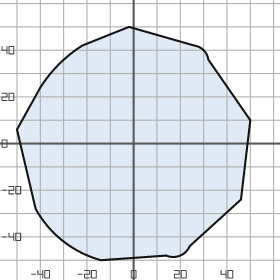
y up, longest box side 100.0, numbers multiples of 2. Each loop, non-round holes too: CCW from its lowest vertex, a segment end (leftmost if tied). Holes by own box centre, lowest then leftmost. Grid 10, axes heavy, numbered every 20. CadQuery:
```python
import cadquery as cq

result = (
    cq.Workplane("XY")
    .moveTo(-14.0, -50.0)
    .lineTo(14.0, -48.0)
    .threePointArc((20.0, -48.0), (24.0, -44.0))
    .lineTo(46.0, -24.0)
    .lineTo(50.0, 10.0)
    .lineTo(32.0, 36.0)
    .threePointArc((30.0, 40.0), (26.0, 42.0))
    .lineTo(-2.0, 50.0)
    .lineTo(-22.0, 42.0)
    .threePointArc((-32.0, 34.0), (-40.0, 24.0))
    .lineTo(-50.0, 6.0)
    .lineTo(-42.0, -28.0)
    .threePointArc((-30.0, -42.0), (-14.0, -50.0))
    .close()
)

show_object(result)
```